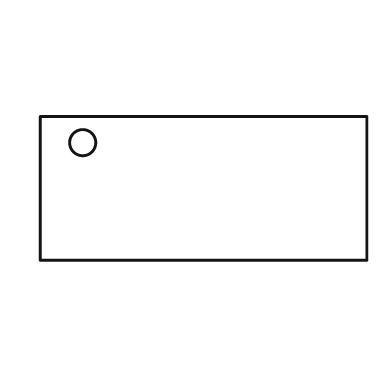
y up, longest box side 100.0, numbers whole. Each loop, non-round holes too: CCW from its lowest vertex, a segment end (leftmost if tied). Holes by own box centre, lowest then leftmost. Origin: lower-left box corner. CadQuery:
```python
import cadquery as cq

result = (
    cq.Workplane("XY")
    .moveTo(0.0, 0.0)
    .lineTo(100.0, 0.0)
    .lineTo(100.0, 44.0)
    .lineTo(0.0, 44.0)
    .close()
    .moveTo(13.0, 36.0)
    .circle(4.0)
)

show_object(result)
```